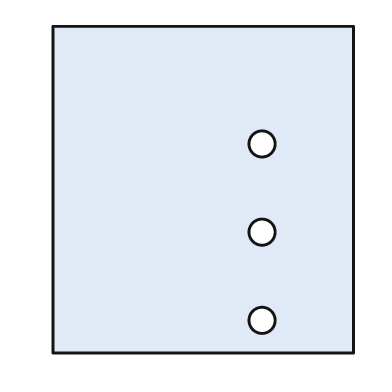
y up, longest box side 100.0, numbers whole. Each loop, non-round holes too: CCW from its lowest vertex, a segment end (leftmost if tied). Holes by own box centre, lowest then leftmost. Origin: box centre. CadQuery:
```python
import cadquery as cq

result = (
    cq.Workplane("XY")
    .moveTo(-46.0, -50.0)
    .lineTo(46.0, -50.0)
    .lineTo(46.0, 50.0)
    .lineTo(-46.0, 50.0)
    .close()
    .moveTo(18.0, -40.0)
    .circle(4.0)
    .moveTo(18.0, -13.0)
    .circle(4.0)
    .moveTo(18.0, 14.0)
    .circle(4.0)
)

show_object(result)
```